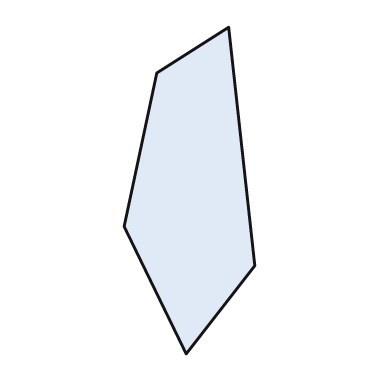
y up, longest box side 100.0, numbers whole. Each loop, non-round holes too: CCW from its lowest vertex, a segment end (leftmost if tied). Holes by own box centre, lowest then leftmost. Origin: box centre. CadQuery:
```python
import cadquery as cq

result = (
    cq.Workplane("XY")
    .moveTo(-1.0, -50.0)
    .lineTo(20.0, -23.0)
    .lineTo(12.0, 50.0)
    .lineTo(-10.0, 36.0)
    .lineTo(-20.0, -11.0)
    .close()
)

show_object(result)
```